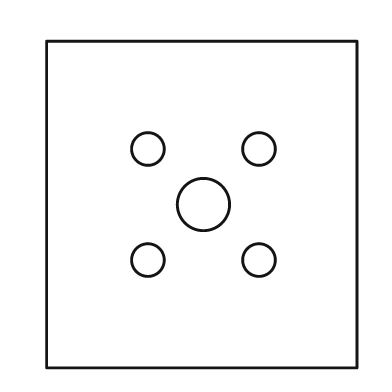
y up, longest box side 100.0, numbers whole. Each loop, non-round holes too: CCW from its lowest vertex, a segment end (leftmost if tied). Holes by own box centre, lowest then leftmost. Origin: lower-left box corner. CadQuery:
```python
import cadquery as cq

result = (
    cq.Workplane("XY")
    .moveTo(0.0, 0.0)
    .lineTo(95.0, 0.0)
    .lineTo(95.0, 100.0)
    .lineTo(0.0, 100.0)
    .close()
    .moveTo(31.0, 33.0)
    .circle(5.0)
    .moveTo(65.0, 33.0)
    .circle(5.0)
    .moveTo(48.0, 50.0)
    .circle(8.0)
    .moveTo(31.0, 67.0)
    .circle(5.0)
    .moveTo(65.0, 67.0)
    .circle(5.0)
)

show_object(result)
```